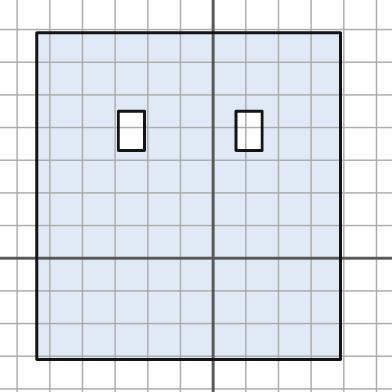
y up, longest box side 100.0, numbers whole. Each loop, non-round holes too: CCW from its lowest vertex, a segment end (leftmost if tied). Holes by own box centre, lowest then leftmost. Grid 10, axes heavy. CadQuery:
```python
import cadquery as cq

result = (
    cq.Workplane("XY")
    .moveTo(-54.0, -31.0)
    .lineTo(39.0, -31.0)
    .lineTo(39.0, 69.0)
    .lineTo(-54.0, 69.0)
    .close()
    .moveTo(-29.0, 33.0)
    .lineTo(-21.0, 33.0)
    .lineTo(-21.0, 45.0)
    .lineTo(-29.0, 45.0)
    .close()
    .moveTo(7.0, 33.0)
    .lineTo(15.0, 33.0)
    .lineTo(15.0, 45.0)
    .lineTo(7.0, 45.0)
    .close()
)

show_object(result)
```